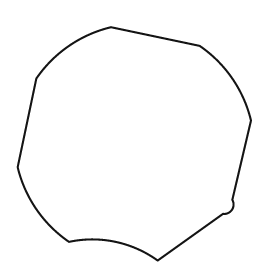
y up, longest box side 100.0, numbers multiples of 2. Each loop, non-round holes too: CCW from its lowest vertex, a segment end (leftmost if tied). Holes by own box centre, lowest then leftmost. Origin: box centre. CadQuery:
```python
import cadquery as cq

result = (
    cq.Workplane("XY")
    .moveTo(10.0, -50.0)
    .lineTo(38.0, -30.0)
    .threePointArc((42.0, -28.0), (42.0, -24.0))
    .lineTo(50.0, 10.0)
    .threePointArc((42.0, 28.0), (28.0, 42.0))
    .lineTo(-10.0, 50.0)
    .threePointArc((-28.0, 42.0), (-42.0, 28.0))
    .lineTo(-50.0, -10.0)
    .threePointArc((-42.0, -28.0), (-28.0, -42.0))
    .threePointArc((-8.0, -42.0), (10.0, -50.0))
    .close()
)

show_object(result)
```